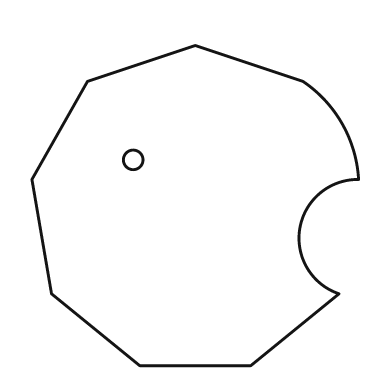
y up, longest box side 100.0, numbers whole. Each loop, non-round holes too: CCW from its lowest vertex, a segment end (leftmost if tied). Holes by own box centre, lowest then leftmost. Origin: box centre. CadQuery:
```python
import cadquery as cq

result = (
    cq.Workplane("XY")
    .moveTo(-17.0, -49.0)
    .lineTo(17.0, -49.0)
    .lineTo(44.0, -27.0)
    .threePointArc((32.0, -7.0), (50.0, 8.0))
    .threePointArc((45.0, 25.0), (33.0, 38.0))
    .lineTo(0.0, 49.0)
    .lineTo(-33.0, 38.0)
    .lineTo(-50.0, 8.0)
    .lineTo(-44.0, -27.0)
    .close()
    .moveTo(-19.0, 14.0)
    .circle(3.0)
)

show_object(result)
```